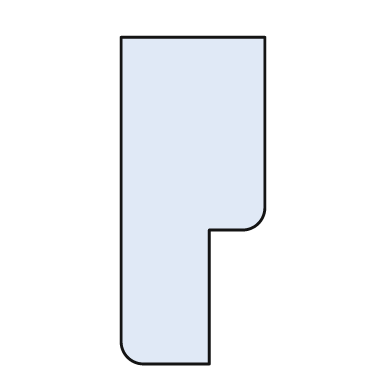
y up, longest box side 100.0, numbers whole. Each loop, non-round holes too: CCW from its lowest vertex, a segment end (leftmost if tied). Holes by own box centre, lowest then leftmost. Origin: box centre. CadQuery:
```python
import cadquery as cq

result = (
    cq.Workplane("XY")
    .moveTo(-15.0, -50.0)
    .lineTo(5.0, -50.0)
    .lineTo(5.0, -9.0)
    .lineTo(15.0, -9.0)
    .threePointArc((20.0, -7.0), (22.0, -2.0))
    .lineTo(22.0, 50.0)
    .lineTo(-22.0, 50.0)
    .lineTo(-22.0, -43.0)
    .threePointArc((-20.0, -48.0), (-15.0, -50.0))
    .close()
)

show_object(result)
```